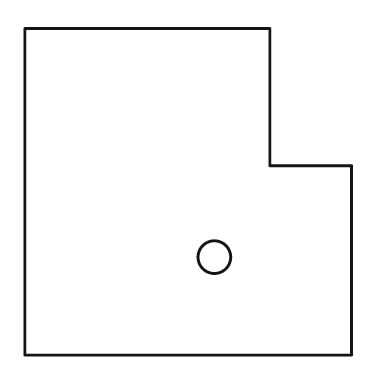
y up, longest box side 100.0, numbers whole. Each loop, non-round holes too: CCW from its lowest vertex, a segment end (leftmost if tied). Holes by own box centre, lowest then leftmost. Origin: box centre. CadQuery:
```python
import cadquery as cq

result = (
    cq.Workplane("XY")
    .moveTo(-50.0, -50.0)
    .lineTo(50.0, -50.0)
    .lineTo(50.0, 8.0)
    .lineTo(25.0, 8.0)
    .lineTo(25.0, 50.0)
    .lineTo(-50.0, 50.0)
    .close()
    .moveTo(8.0, -20.0)
    .circle(5.0)
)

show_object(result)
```